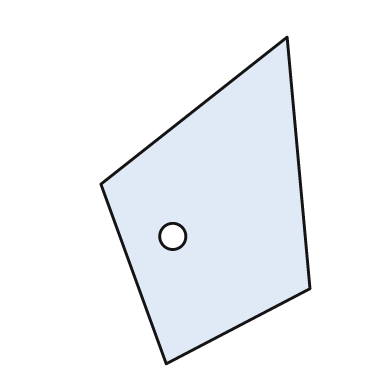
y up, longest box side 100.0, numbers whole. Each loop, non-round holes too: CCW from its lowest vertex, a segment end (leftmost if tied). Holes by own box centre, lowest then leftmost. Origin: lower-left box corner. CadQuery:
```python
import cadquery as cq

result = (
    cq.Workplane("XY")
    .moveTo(20.0, 0.0)
    .lineTo(64.0, 23.0)
    .lineTo(57.0, 100.0)
    .lineTo(0.0, 55.0)
    .close()
    .moveTo(22.0, 39.0)
    .circle(4.0)
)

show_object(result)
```